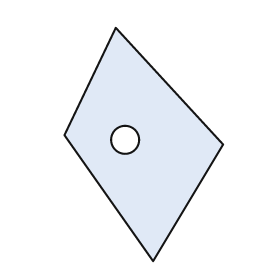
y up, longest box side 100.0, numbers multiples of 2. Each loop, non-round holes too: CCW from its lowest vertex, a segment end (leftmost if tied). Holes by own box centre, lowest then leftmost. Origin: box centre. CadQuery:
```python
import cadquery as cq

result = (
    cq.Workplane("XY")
    .moveTo(4.0, -50.0)
    .lineTo(34.0, 0.0)
    .lineTo(-12.0, 50.0)
    .lineTo(-34.0, 4.0)
    .close()
    .moveTo(-8.0, 2.0)
    .circle(6.0)
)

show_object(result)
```